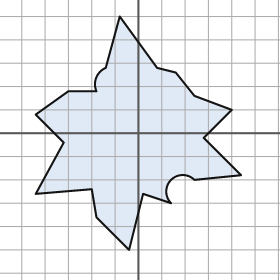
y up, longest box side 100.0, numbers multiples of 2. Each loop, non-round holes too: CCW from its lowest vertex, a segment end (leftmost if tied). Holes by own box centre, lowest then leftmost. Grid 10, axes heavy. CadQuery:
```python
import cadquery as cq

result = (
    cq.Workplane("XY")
    .moveTo(-4.0, -50.0)
    .lineTo(2.0, -26.0)
    .lineTo(14.0, -30.0)
    .threePointArc((14.0, -20.0), (24.0, -20.0))
    .lineTo(44.0, -18.0)
    .lineTo(28.0, -2.0)
    .lineTo(40.0, 10.0)
    .lineTo(24.0, 16.0)
    .lineTo(16.0, 26.0)
    .lineTo(8.0, 28.0)
    .lineTo(-8.0, 50.0)
    .lineTo(-14.0, 28.0)
    .threePointArc((-18.0, 24.0), (-18.0, 18.0))
    .lineTo(-30.0, 18.0)
    .lineTo(-44.0, 8.0)
    .lineTo(-32.0, -4.0)
    .lineTo(-44.0, -26.0)
    .lineTo(-20.0, -24.0)
    .lineTo(-18.0, -36.0)
    .close()
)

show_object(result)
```